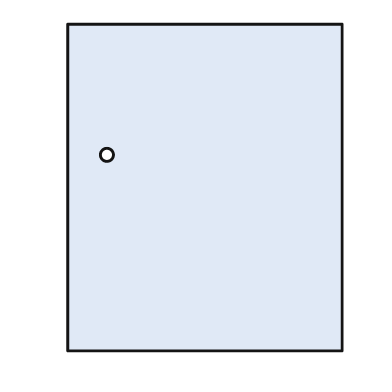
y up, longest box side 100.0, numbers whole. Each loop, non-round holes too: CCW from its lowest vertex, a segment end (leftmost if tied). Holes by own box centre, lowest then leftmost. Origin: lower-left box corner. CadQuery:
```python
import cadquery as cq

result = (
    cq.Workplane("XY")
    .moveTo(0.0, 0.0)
    .lineTo(84.0, 0.0)
    .lineTo(84.0, 100.0)
    .lineTo(0.0, 100.0)
    .close()
    .moveTo(12.0, 60.0)
    .circle(2.0)
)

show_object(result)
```